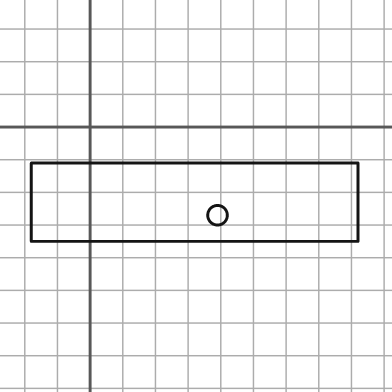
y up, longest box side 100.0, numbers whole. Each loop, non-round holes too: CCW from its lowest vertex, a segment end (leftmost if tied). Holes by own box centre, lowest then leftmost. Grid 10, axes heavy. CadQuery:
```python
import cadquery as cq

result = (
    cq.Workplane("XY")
    .moveTo(-18.0, -35.0)
    .lineTo(82.0, -35.0)
    .lineTo(82.0, -11.0)
    .lineTo(-18.0, -11.0)
    .close()
    .moveTo(39.0, -27.0)
    .circle(3.0)
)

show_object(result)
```